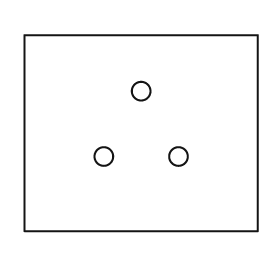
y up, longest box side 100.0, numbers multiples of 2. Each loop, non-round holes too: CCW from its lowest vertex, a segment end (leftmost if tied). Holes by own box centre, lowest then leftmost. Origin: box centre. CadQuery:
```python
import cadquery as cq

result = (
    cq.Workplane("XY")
    .moveTo(-50.0, -42.0)
    .lineTo(50.0, -42.0)
    .lineTo(50.0, 42.0)
    .lineTo(-50.0, 42.0)
    .close()
    .moveTo(-16.0, -10.0)
    .circle(4.0)
    .moveTo(16.0, -10.0)
    .circle(4.0)
    .moveTo(0.0, 18.0)
    .circle(4.0)
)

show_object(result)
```